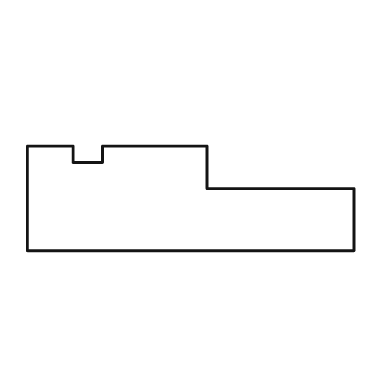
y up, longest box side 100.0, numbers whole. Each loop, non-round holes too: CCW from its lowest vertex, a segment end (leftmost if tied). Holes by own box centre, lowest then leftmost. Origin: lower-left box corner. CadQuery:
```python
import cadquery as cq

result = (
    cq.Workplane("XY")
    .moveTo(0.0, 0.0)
    .lineTo(100.0, 0.0)
    .lineTo(100.0, 19.0)
    .lineTo(55.0, 19.0)
    .lineTo(55.0, 32.0)
    .lineTo(23.0, 32.0)
    .lineTo(23.0, 27.0)
    .lineTo(14.0, 27.0)
    .lineTo(14.0, 32.0)
    .lineTo(0.0, 32.0)
    .close()
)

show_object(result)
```